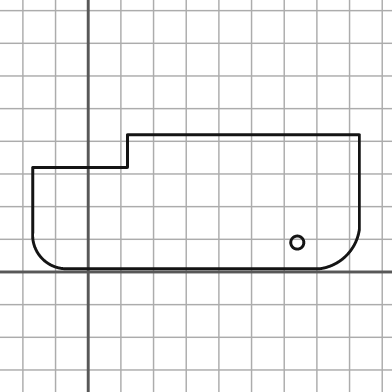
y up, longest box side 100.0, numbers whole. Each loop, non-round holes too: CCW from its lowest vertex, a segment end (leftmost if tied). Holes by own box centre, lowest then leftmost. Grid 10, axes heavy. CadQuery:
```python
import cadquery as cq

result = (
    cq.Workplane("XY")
    .moveTo(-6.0, 1.0)
    .lineTo(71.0, 1.0)
    .threePointArc((79.0, 5.0), (83.0, 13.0))
    .lineTo(83.0, 42.0)
    .lineTo(12.0, 42.0)
    .lineTo(12.0, 32.0)
    .lineTo(-17.0, 32.0)
    .lineTo(-17.0, 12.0)
    .threePointArc((-14.0, 4.0), (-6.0, 1.0))
    .close()
    .moveTo(64.0, 9.0)
    .circle(2.0)
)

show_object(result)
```